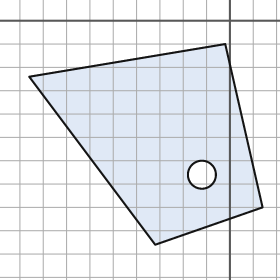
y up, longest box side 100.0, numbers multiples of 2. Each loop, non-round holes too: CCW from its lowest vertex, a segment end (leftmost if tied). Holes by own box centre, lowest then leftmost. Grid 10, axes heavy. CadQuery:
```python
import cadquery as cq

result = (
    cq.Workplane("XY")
    .moveTo(-32.0, -96.0)
    .lineTo(14.0, -80.0)
    .lineTo(-2.0, -10.0)
    .lineTo(-86.0, -24.0)
    .close()
    .moveTo(-12.0, -66.0)
    .circle(6.0)
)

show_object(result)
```